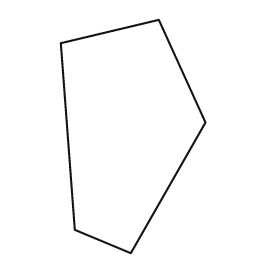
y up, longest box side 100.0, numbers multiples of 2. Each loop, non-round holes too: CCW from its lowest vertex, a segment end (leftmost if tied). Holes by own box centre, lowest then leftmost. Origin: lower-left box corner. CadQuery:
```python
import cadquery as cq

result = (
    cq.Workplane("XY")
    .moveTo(30.0, 0.0)
    .lineTo(62.0, 56.0)
    .lineTo(42.0, 100.0)
    .lineTo(0.0, 90.0)
    .lineTo(6.0, 10.0)
    .close()
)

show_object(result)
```